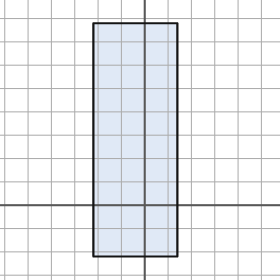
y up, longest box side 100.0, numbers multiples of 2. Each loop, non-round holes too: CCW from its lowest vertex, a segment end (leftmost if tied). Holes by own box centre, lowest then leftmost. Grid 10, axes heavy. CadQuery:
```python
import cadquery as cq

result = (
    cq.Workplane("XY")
    .moveTo(-22.0, -22.0)
    .lineTo(14.0, -22.0)
    .lineTo(14.0, 78.0)
    .lineTo(-22.0, 78.0)
    .close()
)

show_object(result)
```